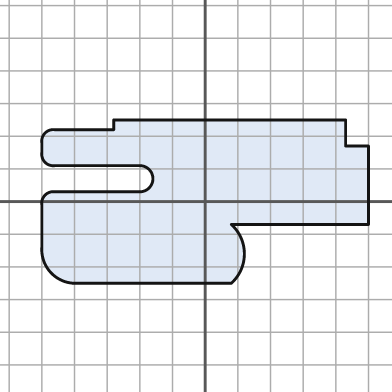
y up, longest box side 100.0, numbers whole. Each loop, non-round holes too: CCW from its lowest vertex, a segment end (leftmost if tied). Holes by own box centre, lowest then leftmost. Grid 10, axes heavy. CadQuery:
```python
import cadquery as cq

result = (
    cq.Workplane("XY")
    .moveTo(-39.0, -25.0)
    .lineTo(8.0, -25.0)
    .threePointArc((12.0, -16.0), (8.0, -7.0))
    .lineTo(50.0, -7.0)
    .lineTo(50.0, 17.0)
    .lineTo(43.0, 17.0)
    .lineTo(43.0, 25.0)
    .lineTo(-28.0, 25.0)
    .lineTo(-28.0, 22.0)
    .lineTo(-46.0, 22.0)
    .threePointArc((-49.0, 21.0), (-50.0, 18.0))
    .lineTo(-50.0, 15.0)
    .threePointArc((-49.0, 12.0), (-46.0, 11.0))
    .lineTo(-20.0, 11.0)
    .threePointArc((-16.0, 7.0), (-20.0, 3.0))
    .lineTo(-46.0, 3.0)
    .threePointArc((-49.0, 2.0), (-50.0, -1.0))
    .lineTo(-50.0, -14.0)
    .threePointArc((-47.0, -22.0), (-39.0, -25.0))
    .close()
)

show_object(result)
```